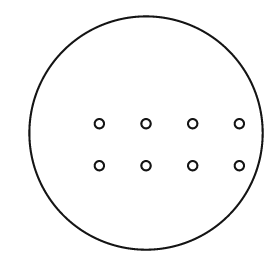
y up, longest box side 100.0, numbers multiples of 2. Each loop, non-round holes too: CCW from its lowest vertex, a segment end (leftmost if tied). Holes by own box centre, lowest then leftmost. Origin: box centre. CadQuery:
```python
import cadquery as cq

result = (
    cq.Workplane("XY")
    .moveTo(0.0, 0.0)
    .circle(50.0)
    .moveTo(-20.0, -14.0)
    .circle(2.0)
    .moveTo(0.0, -14.0)
    .circle(2.0)
    .moveTo(20.0, -14.0)
    .circle(2.0)
    .moveTo(40.0, -14.0)
    .circle(2.0)
    .moveTo(-20.0, 4.0)
    .circle(2.0)
    .moveTo(0.0, 4.0)
    .circle(2.0)
    .moveTo(20.0, 4.0)
    .circle(2.0)
    .moveTo(40.0, 4.0)
    .circle(2.0)
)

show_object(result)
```